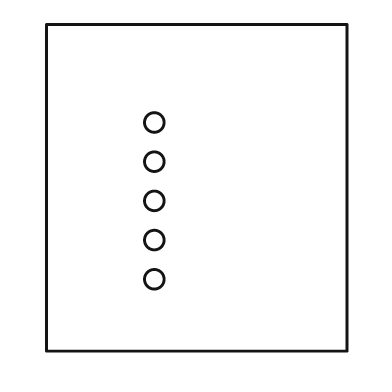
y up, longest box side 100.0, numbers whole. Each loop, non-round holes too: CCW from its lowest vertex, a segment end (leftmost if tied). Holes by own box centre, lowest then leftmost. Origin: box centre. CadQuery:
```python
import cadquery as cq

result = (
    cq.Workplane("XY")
    .moveTo(-46.0, -50.0)
    .lineTo(46.0, -50.0)
    .lineTo(46.0, 50.0)
    .lineTo(-46.0, 50.0)
    .close()
    .moveTo(-13.0, -28.0)
    .circle(3.0)
    .moveTo(-13.0, -16.0)
    .circle(3.0)
    .moveTo(-13.0, -4.0)
    .circle(3.0)
    .moveTo(-13.0, 8.0)
    .circle(3.0)
    .moveTo(-13.0, 20.0)
    .circle(3.0)
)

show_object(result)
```